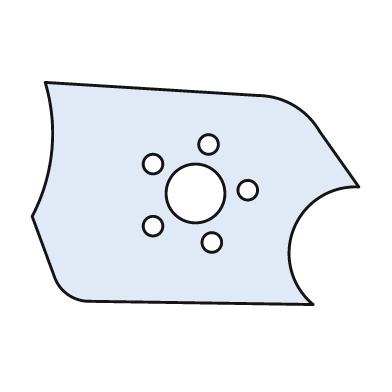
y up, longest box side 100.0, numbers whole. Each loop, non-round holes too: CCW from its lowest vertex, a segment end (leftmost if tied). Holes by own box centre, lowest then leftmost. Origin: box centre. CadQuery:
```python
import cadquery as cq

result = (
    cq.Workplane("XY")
    .moveTo(36.0, -34.0)
    .threePointArc((30.0, -11.0), (50.0, 2.0))
    .lineTo(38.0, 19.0)
    .threePointArc((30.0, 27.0), (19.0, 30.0))
    .lineTo(-46.0, 34.0)
    .threePointArc((-44.0, 13.0), (-50.0, -7.0))
    .lineTo(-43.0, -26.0)
    .threePointArc((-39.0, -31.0), (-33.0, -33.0))
    .close()
    .moveTo(5.0, -15.0)
    .circle(3.0)
    .moveTo(-13.0, -10.0)
    .circle(3.0)
    .moveTo(0.0, 0.0)
    .circle(9.0)
    .moveTo(16.0, 1.0)
    .circle(3.0)
    .moveTo(-13.0, 9.0)
    .circle(3.0)
    .moveTo(4.0, 15.0)
    .circle(3.0)
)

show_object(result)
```